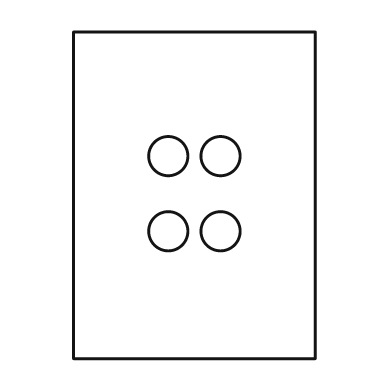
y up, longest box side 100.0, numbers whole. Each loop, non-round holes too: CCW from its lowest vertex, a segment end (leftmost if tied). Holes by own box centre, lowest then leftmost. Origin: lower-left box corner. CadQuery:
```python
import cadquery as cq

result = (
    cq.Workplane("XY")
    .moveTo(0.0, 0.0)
    .lineTo(74.0, 0.0)
    .lineTo(74.0, 100.0)
    .lineTo(0.0, 100.0)
    .close()
    .moveTo(29.0, 39.0)
    .circle(6.0)
    .moveTo(45.0, 39.0)
    .circle(6.0)
    .moveTo(29.0, 62.0)
    .circle(6.0)
    .moveTo(45.0, 62.0)
    .circle(6.0)
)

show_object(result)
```